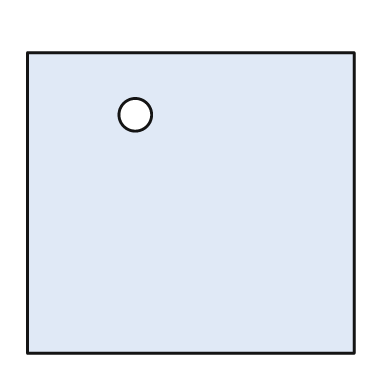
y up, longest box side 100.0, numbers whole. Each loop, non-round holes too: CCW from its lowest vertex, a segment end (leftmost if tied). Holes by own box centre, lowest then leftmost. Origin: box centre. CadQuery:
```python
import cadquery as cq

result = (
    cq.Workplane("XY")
    .moveTo(-50.0, -46.0)
    .lineTo(50.0, -46.0)
    .lineTo(50.0, 46.0)
    .lineTo(-50.0, 46.0)
    .close()
    .moveTo(-17.0, 27.0)
    .circle(5.0)
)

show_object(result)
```